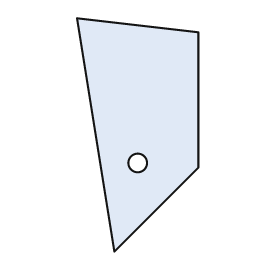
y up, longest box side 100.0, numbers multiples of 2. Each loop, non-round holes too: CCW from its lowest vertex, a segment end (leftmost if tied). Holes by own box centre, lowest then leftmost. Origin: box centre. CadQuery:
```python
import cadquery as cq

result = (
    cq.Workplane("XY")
    .moveTo(-10.0, -50.0)
    .lineTo(26.0, -14.0)
    .lineTo(26.0, 44.0)
    .lineTo(-26.0, 50.0)
    .close()
    .moveTo(0.0, -12.0)
    .circle(4.0)
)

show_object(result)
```